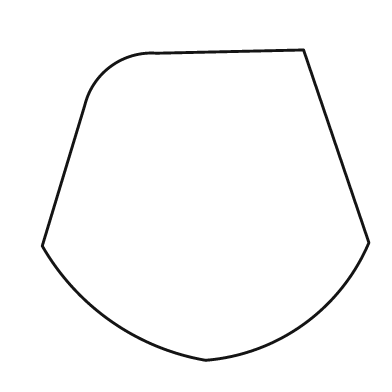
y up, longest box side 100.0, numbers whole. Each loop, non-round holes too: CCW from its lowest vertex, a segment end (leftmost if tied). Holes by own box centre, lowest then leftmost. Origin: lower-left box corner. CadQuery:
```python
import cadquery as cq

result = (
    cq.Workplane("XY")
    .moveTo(50.0, 0.0)
    .threePointArc((80.0, 11.0), (100.0, 36.0))
    .lineTo(80.0, 95.0)
    .lineTo(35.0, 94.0)
    .threePointArc((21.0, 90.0), (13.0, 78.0))
    .lineTo(0.0, 35.0)
    .threePointArc((21.0, 12.0), (50.0, 0.0))
    .close()
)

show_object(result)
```